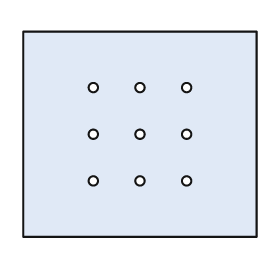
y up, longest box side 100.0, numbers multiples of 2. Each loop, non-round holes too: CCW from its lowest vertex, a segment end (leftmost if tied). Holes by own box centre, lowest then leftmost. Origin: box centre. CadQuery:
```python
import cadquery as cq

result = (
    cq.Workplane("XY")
    .moveTo(-50.0, -44.0)
    .lineTo(50.0, -44.0)
    .lineTo(50.0, 44.0)
    .lineTo(-50.0, 44.0)
    .close()
    .moveTo(-20.0, -20.0)
    .circle(2.0)
    .moveTo(0.0, -20.0)
    .circle(2.0)
    .moveTo(20.0, -20.0)
    .circle(2.0)
    .moveTo(-20.0, 0.0)
    .circle(2.0)
    .moveTo(0.0, 0.0)
    .circle(2.0)
    .moveTo(20.0, 0.0)
    .circle(2.0)
    .moveTo(-20.0, 20.0)
    .circle(2.0)
    .moveTo(0.0, 20.0)
    .circle(2.0)
    .moveTo(20.0, 20.0)
    .circle(2.0)
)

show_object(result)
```